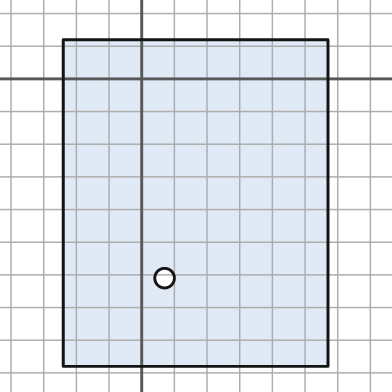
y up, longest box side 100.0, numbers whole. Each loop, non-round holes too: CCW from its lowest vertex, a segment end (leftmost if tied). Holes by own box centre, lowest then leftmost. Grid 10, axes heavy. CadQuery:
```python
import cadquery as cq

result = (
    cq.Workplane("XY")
    .moveTo(-24.0, -88.0)
    .lineTo(57.0, -88.0)
    .lineTo(57.0, 12.0)
    .lineTo(-24.0, 12.0)
    .close()
    .moveTo(7.0, -61.0)
    .circle(3.0)
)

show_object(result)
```